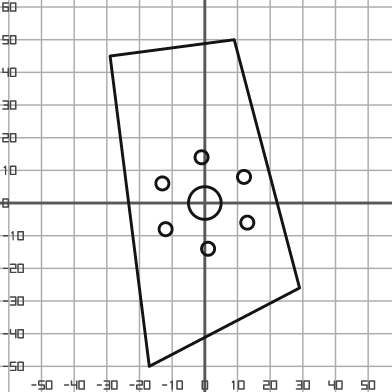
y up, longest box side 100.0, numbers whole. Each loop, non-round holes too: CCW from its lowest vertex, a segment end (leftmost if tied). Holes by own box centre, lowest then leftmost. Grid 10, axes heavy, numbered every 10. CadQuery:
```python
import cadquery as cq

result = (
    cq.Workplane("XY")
    .moveTo(-17.0, -50.0)
    .lineTo(29.0, -26.0)
    .lineTo(9.0, 50.0)
    .lineTo(-29.0, 45.0)
    .close()
    .moveTo(1.0, -14.0)
    .circle(2.0)
    .moveTo(-12.0, -8.0)
    .circle(2.0)
    .moveTo(13.0, -6.0)
    .circle(2.0)
    .moveTo(0.0, 0.0)
    .circle(5.0)
    .moveTo(-13.0, 6.0)
    .circle(2.0)
    .moveTo(12.0, 8.0)
    .circle(2.0)
    .moveTo(-1.0, 14.0)
    .circle(2.0)
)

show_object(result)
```